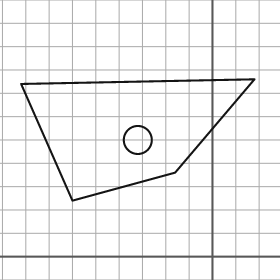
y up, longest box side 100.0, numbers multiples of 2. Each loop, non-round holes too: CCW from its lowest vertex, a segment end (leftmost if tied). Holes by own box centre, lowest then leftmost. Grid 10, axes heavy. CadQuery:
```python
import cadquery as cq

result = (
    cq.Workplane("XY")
    .moveTo(-60.0, 24.0)
    .lineTo(-16.0, 36.0)
    .lineTo(18.0, 76.0)
    .lineTo(-82.0, 74.0)
    .close()
    .moveTo(-32.0, 50.0)
    .circle(6.0)
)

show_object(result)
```